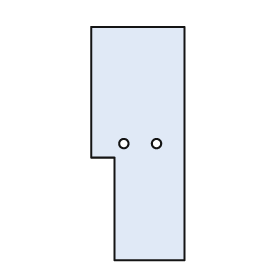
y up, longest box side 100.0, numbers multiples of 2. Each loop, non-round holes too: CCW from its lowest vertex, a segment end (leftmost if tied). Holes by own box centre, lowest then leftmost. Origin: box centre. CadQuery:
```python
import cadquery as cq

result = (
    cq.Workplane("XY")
    .moveTo(-10.0, -50.0)
    .lineTo(20.0, -50.0)
    .lineTo(20.0, 50.0)
    .lineTo(-20.0, 50.0)
    .lineTo(-20.0, -6.0)
    .lineTo(-10.0, -6.0)
    .close()
    .moveTo(-6.0, 0.0)
    .circle(2.0)
    .moveTo(8.0, 0.0)
    .circle(2.0)
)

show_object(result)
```